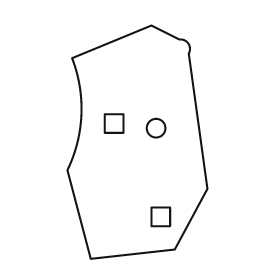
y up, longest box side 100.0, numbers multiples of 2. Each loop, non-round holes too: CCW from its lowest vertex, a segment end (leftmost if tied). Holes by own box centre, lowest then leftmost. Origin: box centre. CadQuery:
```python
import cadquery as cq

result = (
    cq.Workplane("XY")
    .moveTo(-20.0, -50.0)
    .lineTo(16.0, -46.0)
    .lineTo(30.0, -20.0)
    .lineTo(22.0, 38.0)
    .threePointArc((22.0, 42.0), (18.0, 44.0))
    .lineTo(6.0, 50.0)
    .lineTo(-28.0, 36.0)
    .threePointArc((-24.0, 12.0), (-30.0, -12.0))
    .close()
    .moveTo(6.0, -36.0)
    .lineTo(14.0, -36.0)
    .lineTo(14.0, -28.0)
    .lineTo(6.0, -28.0)
    .close()
    .moveTo(8.0, 6.0)
    .circle(4.0)
    .moveTo(-14.0, 4.0)
    .lineTo(-6.0, 4.0)
    .lineTo(-6.0, 12.0)
    .lineTo(-14.0, 12.0)
    .close()
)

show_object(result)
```